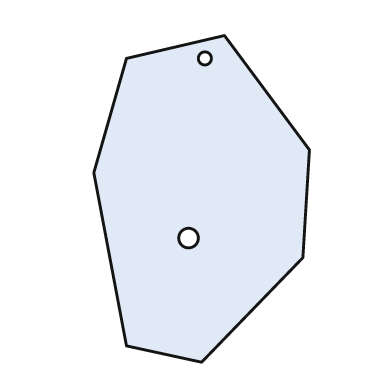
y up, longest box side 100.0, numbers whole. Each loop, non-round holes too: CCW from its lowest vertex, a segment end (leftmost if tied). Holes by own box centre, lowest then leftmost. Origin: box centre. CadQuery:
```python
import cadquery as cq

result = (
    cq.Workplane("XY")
    .moveTo(0.0, -50.0)
    .lineTo(31.0, -18.0)
    .lineTo(33.0, 15.0)
    .lineTo(7.0, 50.0)
    .lineTo(-23.0, 43.0)
    .lineTo(-33.0, 8.0)
    .lineTo(-23.0, -45.0)
    .close()
    .moveTo(-4.0, -12.0)
    .circle(3.0)
    .moveTo(1.0, 43.0)
    .circle(2.0)
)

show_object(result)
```